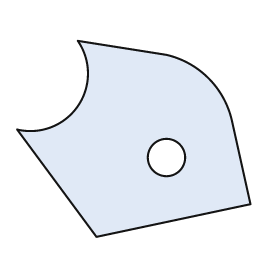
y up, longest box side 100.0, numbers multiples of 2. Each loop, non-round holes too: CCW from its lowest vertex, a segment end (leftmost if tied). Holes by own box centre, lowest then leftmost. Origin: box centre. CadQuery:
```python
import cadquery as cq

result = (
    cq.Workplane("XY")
    .moveTo(-16.0, -42.0)
    .lineTo(50.0, -28.0)
    .lineTo(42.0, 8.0)
    .threePointArc((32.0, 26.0), (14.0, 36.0))
    .lineTo(-24.0, 42.0)
    .threePointArc((-24.0, 14.0), (-50.0, 4.0))
    .close()
    .moveTo(14.0, -8.0)
    .circle(8.0)
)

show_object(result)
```